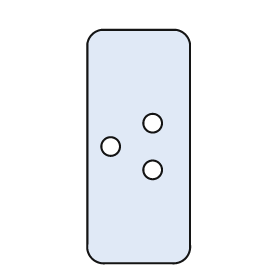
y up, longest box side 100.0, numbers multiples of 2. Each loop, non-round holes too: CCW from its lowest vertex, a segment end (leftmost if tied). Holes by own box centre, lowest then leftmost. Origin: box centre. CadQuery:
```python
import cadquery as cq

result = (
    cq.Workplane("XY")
    .moveTo(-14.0, -50.0)
    .lineTo(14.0, -50.0)
    .threePointArc((20.0, -48.0), (22.0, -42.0))
    .lineTo(22.0, 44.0)
    .threePointArc((20.0, 48.0), (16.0, 50.0))
    .lineTo(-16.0, 50.0)
    .threePointArc((-20.0, 48.0), (-22.0, 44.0))
    .lineTo(-22.0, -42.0)
    .threePointArc((-20.0, -48.0), (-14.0, -50.0))
    .close()
    .moveTo(6.0, -10.0)
    .circle(4.0)
    .moveTo(-12.0, 0.0)
    .circle(4.0)
    .moveTo(6.0, 10.0)
    .circle(4.0)
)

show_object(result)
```